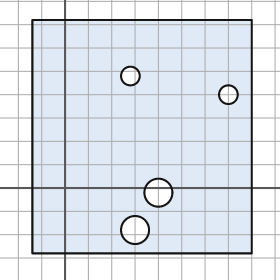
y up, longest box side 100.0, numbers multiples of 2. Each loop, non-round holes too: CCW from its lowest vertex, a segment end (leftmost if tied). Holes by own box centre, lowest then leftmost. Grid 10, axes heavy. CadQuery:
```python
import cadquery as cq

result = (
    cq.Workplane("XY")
    .moveTo(-14.0, -28.0)
    .lineTo(80.0, -28.0)
    .lineTo(80.0, 72.0)
    .lineTo(-14.0, 72.0)
    .close()
    .moveTo(30.0, -18.0)
    .circle(6.0)
    .moveTo(40.0, -2.0)
    .circle(6.0)
    .moveTo(70.0, 40.0)
    .circle(4.0)
    .moveTo(28.0, 48.0)
    .circle(4.0)
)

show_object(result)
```